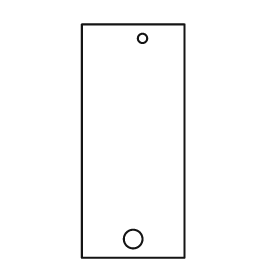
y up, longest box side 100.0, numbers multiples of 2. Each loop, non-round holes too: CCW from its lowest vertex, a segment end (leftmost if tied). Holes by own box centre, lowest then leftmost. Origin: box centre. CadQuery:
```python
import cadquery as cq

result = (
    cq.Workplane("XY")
    .moveTo(-22.0, -50.0)
    .lineTo(22.0, -50.0)
    .lineTo(22.0, 50.0)
    .lineTo(-22.0, 50.0)
    .close()
    .moveTo(0.0, -42.0)
    .circle(4.0)
    .moveTo(4.0, 44.0)
    .circle(2.0)
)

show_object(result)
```